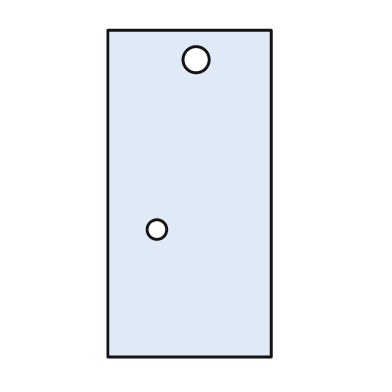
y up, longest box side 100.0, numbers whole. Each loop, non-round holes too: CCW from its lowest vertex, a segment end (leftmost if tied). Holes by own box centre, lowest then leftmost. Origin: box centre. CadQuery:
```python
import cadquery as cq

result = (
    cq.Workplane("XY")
    .moveTo(-25.0, -50.0)
    .lineTo(25.0, -50.0)
    .lineTo(25.0, 50.0)
    .lineTo(-25.0, 50.0)
    .close()
    .moveTo(-10.0, -11.0)
    .circle(3.0)
    .moveTo(2.0, 41.0)
    .circle(4.0)
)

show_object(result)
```